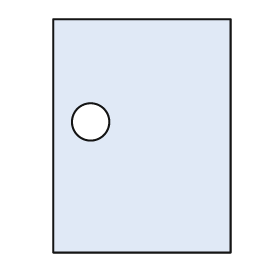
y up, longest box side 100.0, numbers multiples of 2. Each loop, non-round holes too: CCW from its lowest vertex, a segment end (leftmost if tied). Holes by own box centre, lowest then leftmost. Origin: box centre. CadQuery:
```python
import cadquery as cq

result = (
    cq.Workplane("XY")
    .moveTo(-38.0, -50.0)
    .lineTo(38.0, -50.0)
    .lineTo(38.0, 50.0)
    .lineTo(-38.0, 50.0)
    .close()
    .moveTo(-22.0, 6.0)
    .circle(8.0)
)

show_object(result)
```